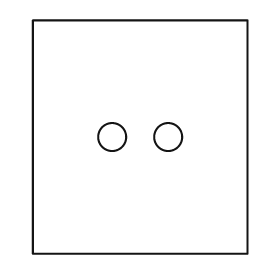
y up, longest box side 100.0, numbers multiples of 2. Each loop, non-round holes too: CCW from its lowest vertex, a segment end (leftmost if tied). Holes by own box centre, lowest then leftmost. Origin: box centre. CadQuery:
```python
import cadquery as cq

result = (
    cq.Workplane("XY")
    .moveTo(-46.0, -50.0)
    .lineTo(46.0, -50.0)
    .lineTo(46.0, 50.0)
    .lineTo(-46.0, 50.0)
    .close()
    .moveTo(-12.0, 0.0)
    .circle(6.0)
    .moveTo(12.0, 0.0)
    .circle(6.0)
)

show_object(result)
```